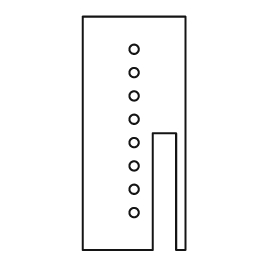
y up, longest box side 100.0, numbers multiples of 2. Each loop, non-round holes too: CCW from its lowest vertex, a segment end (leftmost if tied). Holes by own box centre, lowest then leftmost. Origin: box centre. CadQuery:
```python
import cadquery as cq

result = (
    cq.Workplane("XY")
    .moveTo(-22.0, -50.0)
    .lineTo(8.0, -50.0)
    .lineTo(8.0, 0.0)
    .lineTo(18.0, 0.0)
    .lineTo(18.0, -50.0)
    .lineTo(22.0, -50.0)
    .lineTo(22.0, 50.0)
    .lineTo(-22.0, 50.0)
    .close()
    .moveTo(0.0, -34.0)
    .circle(2.0)
    .moveTo(0.0, -24.0)
    .circle(2.0)
    .moveTo(0.0, -14.0)
    .circle(2.0)
    .moveTo(0.0, -4.0)
    .circle(2.0)
    .moveTo(0.0, 6.0)
    .circle(2.0)
    .moveTo(0.0, 16.0)
    .circle(2.0)
    .moveTo(0.0, 26.0)
    .circle(2.0)
    .moveTo(0.0, 36.0)
    .circle(2.0)
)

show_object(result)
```